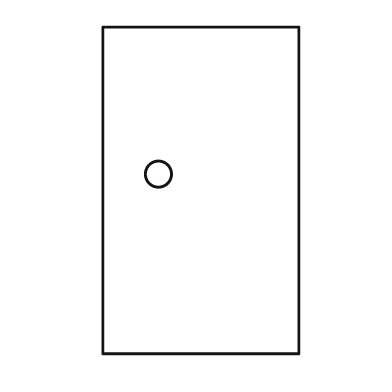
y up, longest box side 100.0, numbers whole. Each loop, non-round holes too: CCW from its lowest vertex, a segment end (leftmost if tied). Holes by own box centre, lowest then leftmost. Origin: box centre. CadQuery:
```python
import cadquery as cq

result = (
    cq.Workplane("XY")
    .moveTo(-30.0, -50.0)
    .lineTo(30.0, -50.0)
    .lineTo(30.0, 50.0)
    .lineTo(-30.0, 50.0)
    .close()
    .moveTo(-13.0, 5.0)
    .circle(4.0)
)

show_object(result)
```